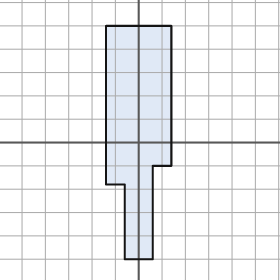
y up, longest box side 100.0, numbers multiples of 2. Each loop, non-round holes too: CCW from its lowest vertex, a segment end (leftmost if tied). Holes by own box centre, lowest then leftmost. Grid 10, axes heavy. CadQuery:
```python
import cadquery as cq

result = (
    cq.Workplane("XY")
    .moveTo(-6.0, -50.0)
    .lineTo(6.0, -50.0)
    .lineTo(6.0, -10.0)
    .lineTo(14.0, -10.0)
    .lineTo(14.0, 50.0)
    .lineTo(-14.0, 50.0)
    .lineTo(-14.0, -18.0)
    .lineTo(-6.0, -18.0)
    .close()
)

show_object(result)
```